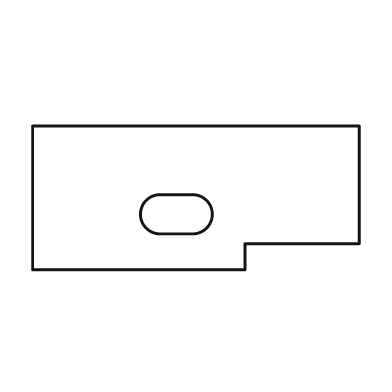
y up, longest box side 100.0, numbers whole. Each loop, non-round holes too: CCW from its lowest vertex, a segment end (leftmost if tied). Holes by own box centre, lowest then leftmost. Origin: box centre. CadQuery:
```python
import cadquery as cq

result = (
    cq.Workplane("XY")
    .moveTo(-50.0, -22.0)
    .lineTo(15.0, -22.0)
    .lineTo(15.0, -14.0)
    .lineTo(50.0, -14.0)
    .lineTo(50.0, 22.0)
    .lineTo(-50.0, 22.0)
    .close()
    .moveTo(-11.0, -11.0)
    .lineTo(-1.0, -11.0)
    .threePointArc((5.0, -5.0), (-1.0, 1.0))
    .lineTo(-11.0, 1.0)
    .threePointArc((-17.0, -5.0), (-11.0, -11.0))
    .close()
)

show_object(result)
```